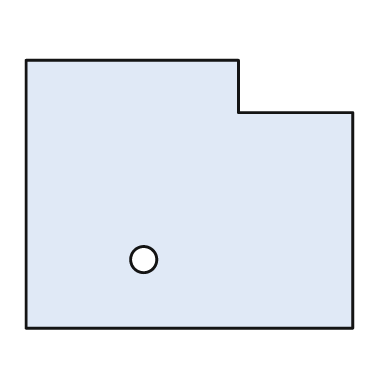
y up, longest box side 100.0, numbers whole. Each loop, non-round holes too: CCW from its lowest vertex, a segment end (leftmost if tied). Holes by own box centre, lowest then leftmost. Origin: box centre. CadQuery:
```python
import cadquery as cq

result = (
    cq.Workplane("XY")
    .moveTo(-50.0, -41.0)
    .lineTo(50.0, -41.0)
    .lineTo(50.0, 25.0)
    .lineTo(15.0, 25.0)
    .lineTo(15.0, 41.0)
    .lineTo(-50.0, 41.0)
    .close()
    .moveTo(-14.0, -20.0)
    .circle(4.0)
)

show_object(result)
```